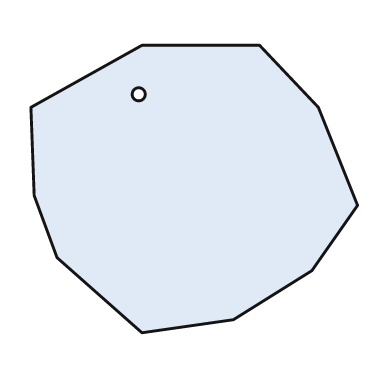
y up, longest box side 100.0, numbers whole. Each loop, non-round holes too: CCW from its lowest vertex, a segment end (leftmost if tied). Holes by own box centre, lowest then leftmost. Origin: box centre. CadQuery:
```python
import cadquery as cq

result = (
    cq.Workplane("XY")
    .moveTo(-16.0, -44.0)
    .lineTo(12.0, -40.0)
    .lineTo(36.0, -25.0)
    .lineTo(50.0, -5.0)
    .lineTo(38.0, 25.0)
    .lineTo(20.0, 44.0)
    .lineTo(-16.0, 44.0)
    .lineTo(-50.0, 25.0)
    .lineTo(-49.0, -2.0)
    .lineTo(-42.0, -21.0)
    .close()
    .moveTo(-17.0, 29.0)
    .circle(2.0)
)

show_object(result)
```